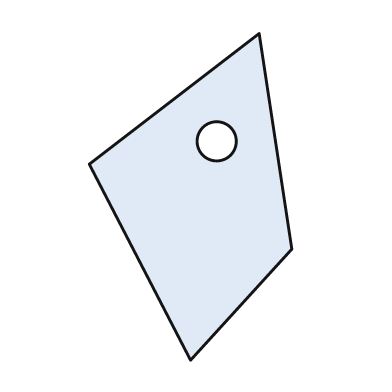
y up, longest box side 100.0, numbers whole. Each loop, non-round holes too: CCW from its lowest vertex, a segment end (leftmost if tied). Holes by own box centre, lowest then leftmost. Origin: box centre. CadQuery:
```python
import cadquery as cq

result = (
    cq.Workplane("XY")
    .moveTo(0.0, -50.0)
    .lineTo(31.0, -16.0)
    .lineTo(21.0, 50.0)
    .lineTo(-31.0, 10.0)
    .close()
    .moveTo(8.0, 17.0)
    .circle(6.0)
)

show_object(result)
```